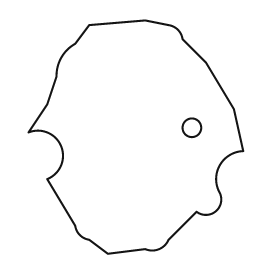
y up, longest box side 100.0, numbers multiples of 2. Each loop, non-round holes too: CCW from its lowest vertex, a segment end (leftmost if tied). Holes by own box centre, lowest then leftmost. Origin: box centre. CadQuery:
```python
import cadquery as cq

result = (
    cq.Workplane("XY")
    .moveTo(-12.0, -50.0)
    .lineTo(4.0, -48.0)
    .threePointArc((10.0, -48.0), (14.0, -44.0))
    .lineTo(26.0, -32.0)
    .threePointArc((34.0, -32.0), (36.0, -24.0))
    .threePointArc((36.0, -12.0), (46.0, -6.0))
    .lineTo(42.0, 12.0)
    .lineTo(30.0, 32.0)
    .lineTo(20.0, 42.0)
    .threePointArc((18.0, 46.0), (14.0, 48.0))
    .lineTo(4.0, 50.0)
    .lineTo(-20.0, 48.0)
    .lineTo(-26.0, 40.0)
    .threePointArc((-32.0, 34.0), (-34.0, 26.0))
    .lineTo(-38.0, 14.0)
    .lineTo(-46.0, 2.0)
    .threePointArc((-32.0, -4.0), (-38.0, -18.0))
    .lineTo(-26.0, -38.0)
    .threePointArc((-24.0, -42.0), (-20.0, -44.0))
    .close()
    .moveTo(24.0, 4.0)
    .circle(4.0)
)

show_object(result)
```